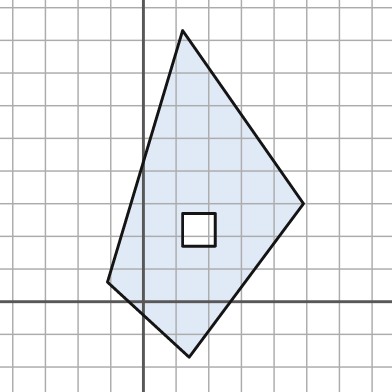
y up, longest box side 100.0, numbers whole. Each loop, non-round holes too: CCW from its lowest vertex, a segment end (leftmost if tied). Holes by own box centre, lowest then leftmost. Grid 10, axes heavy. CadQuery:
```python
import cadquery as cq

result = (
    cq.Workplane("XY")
    .moveTo(14.0, -17.0)
    .lineTo(49.0, 30.0)
    .lineTo(12.0, 83.0)
    .lineTo(-11.0, 6.0)
    .close()
    .moveTo(12.0, 17.0)
    .lineTo(22.0, 17.0)
    .lineTo(22.0, 27.0)
    .lineTo(12.0, 27.0)
    .close()
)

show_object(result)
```